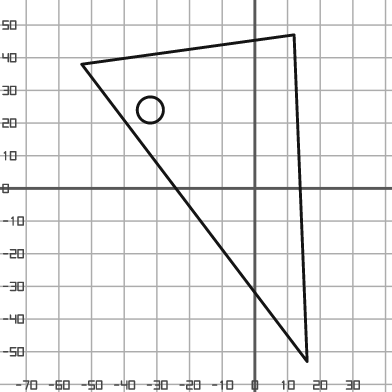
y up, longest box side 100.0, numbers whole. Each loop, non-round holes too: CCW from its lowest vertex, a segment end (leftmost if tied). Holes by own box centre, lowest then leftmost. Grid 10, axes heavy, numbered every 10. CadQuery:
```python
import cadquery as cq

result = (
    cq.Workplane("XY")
    .moveTo(16.0, -53.0)
    .lineTo(12.0, 47.0)
    .lineTo(-53.0, 38.0)
    .close()
    .moveTo(-32.0, 24.0)
    .circle(4.0)
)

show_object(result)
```